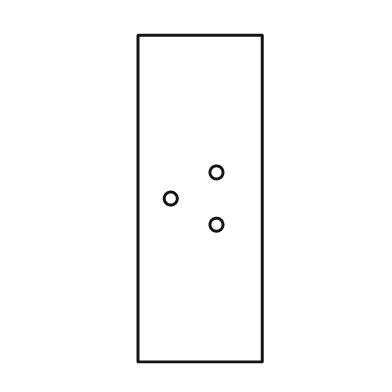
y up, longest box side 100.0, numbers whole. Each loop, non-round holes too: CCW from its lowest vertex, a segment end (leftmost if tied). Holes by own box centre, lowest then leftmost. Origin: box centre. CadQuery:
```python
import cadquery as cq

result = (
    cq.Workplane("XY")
    .moveTo(-19.0, -50.0)
    .lineTo(19.0, -50.0)
    .lineTo(19.0, 50.0)
    .lineTo(-19.0, 50.0)
    .close()
    .moveTo(5.0, -8.0)
    .circle(2.0)
    .moveTo(-9.0, 0.0)
    .circle(2.0)
    .moveTo(5.0, 8.0)
    .circle(2.0)
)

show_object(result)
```